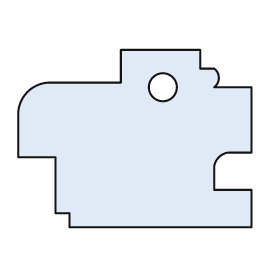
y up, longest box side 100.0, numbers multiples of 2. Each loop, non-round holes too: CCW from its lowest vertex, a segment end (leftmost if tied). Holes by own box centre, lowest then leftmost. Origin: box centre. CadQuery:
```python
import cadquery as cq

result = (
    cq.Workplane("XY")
    .moveTo(-28.0, -38.0)
    .lineTo(50.0, -38.0)
    .lineTo(50.0, -22.0)
    .lineTo(34.0, -22.0)
    .lineTo(34.0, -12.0)
    .threePointArc((36.0, -8.0), (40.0, -6.0))
    .lineTo(50.0, -6.0)
    .lineTo(50.0, 22.0)
    .lineTo(34.0, 22.0)
    .threePointArc((36.0, 26.0), (34.0, 30.0))
    .lineTo(28.0, 30.0)
    .lineTo(28.0, 38.0)
    .lineTo(-6.0, 38.0)
    .lineTo(-6.0, 24.0)
    .lineTo(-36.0, 24.0)
    .threePointArc((-46.0, 20.0), (-50.0, 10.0))
    .lineTo(-50.0, -8.0)
    .lineTo(-34.0, -8.0)
    .lineTo(-34.0, -32.0)
    .lineTo(-28.0, -32.0)
    .close()
    .moveTo(12.0, 22.0)
    .circle(6.0)
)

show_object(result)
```